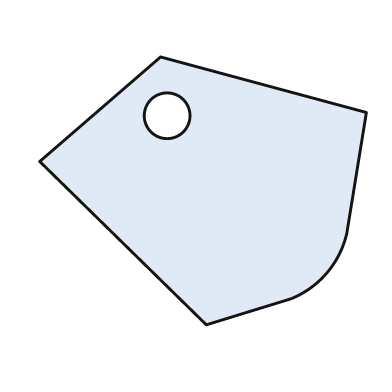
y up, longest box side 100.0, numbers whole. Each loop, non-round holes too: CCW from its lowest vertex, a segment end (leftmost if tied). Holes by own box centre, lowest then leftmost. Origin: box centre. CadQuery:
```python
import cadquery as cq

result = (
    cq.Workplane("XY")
    .moveTo(1.0, -41.0)
    .lineTo(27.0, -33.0)
    .threePointArc((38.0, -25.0), (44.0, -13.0))
    .lineTo(50.0, 24.0)
    .lineTo(-13.0, 41.0)
    .lineTo(-50.0, 9.0)
    .close()
    .moveTo(-11.0, 23.0)
    .circle(7.0)
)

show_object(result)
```